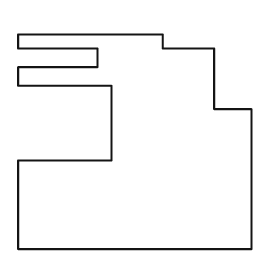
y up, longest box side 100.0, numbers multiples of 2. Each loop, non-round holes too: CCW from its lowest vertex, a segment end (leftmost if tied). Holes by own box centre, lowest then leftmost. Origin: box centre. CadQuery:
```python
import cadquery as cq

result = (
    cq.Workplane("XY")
    .moveTo(-50.0, -46.0)
    .lineTo(50.0, -46.0)
    .lineTo(50.0, 14.0)
    .lineTo(34.0, 14.0)
    .lineTo(34.0, 40.0)
    .lineTo(12.0, 40.0)
    .lineTo(12.0, 46.0)
    .lineTo(-50.0, 46.0)
    .lineTo(-50.0, 40.0)
    .lineTo(-16.0, 40.0)
    .lineTo(-16.0, 32.0)
    .lineTo(-50.0, 32.0)
    .lineTo(-50.0, 24.0)
    .lineTo(-10.0, 24.0)
    .lineTo(-10.0, -8.0)
    .lineTo(-50.0, -8.0)
    .close()
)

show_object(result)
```